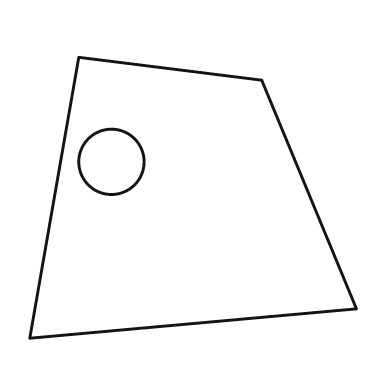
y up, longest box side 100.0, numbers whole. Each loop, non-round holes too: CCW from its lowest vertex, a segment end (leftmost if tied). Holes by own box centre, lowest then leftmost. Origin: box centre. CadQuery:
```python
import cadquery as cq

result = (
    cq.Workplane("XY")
    .moveTo(-50.0, -43.0)
    .lineTo(50.0, -34.0)
    .lineTo(21.0, 36.0)
    .lineTo(-35.0, 43.0)
    .close()
    .moveTo(-25.0, 11.0)
    .circle(10.0)
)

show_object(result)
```